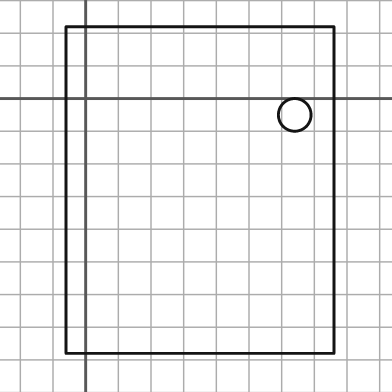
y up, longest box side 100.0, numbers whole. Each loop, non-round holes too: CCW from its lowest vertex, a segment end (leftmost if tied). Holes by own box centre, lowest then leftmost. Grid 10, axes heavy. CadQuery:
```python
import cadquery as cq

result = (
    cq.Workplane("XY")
    .moveTo(-6.0, -78.0)
    .lineTo(76.0, -78.0)
    .lineTo(76.0, 22.0)
    .lineTo(-6.0, 22.0)
    .close()
    .moveTo(64.0, -5.0)
    .circle(5.0)
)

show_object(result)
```